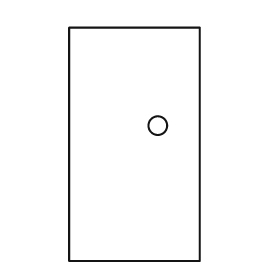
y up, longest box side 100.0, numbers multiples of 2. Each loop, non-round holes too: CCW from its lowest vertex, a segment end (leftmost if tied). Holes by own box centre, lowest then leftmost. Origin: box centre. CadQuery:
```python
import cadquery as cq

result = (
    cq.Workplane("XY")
    .moveTo(-28.0, -50.0)
    .lineTo(28.0, -50.0)
    .lineTo(28.0, 50.0)
    .lineTo(-28.0, 50.0)
    .close()
    .moveTo(10.0, 8.0)
    .circle(4.0)
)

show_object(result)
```